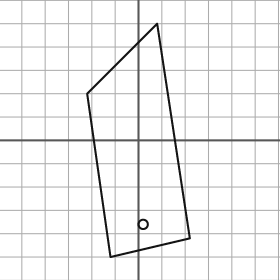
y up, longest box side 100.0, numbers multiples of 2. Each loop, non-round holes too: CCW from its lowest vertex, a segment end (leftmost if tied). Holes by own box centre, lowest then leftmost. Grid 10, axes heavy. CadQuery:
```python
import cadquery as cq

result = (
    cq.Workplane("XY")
    .moveTo(-12.0, -50.0)
    .lineTo(22.0, -42.0)
    .lineTo(8.0, 50.0)
    .lineTo(-22.0, 20.0)
    .close()
    .moveTo(2.0, -36.0)
    .circle(2.0)
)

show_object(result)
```